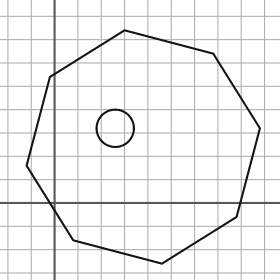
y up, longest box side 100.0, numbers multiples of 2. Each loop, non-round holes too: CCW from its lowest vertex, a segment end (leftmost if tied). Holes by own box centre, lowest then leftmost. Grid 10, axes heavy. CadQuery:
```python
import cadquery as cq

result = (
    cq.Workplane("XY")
    .moveTo(46.0, -26.0)
    .lineTo(78.0, -6.0)
    .lineTo(88.0, 32.0)
    .lineTo(68.0, 64.0)
    .lineTo(30.0, 74.0)
    .lineTo(-2.0, 54.0)
    .lineTo(-12.0, 16.0)
    .lineTo(8.0, -16.0)
    .close()
    .moveTo(26.0, 32.0)
    .circle(8.0)
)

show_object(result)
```